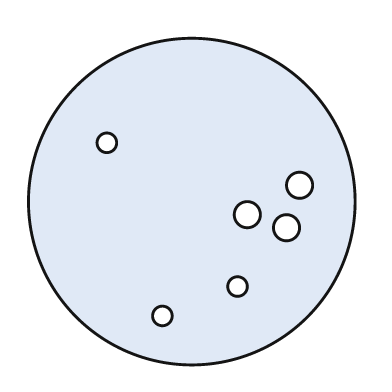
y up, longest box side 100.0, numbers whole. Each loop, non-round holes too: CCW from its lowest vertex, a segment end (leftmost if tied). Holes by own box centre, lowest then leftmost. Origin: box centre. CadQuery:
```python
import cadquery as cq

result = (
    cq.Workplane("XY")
    .moveTo(0.0, 0.0)
    .circle(50.0)
    .moveTo(-9.0, -35.0)
    .circle(3.0)
    .moveTo(14.0, -26.0)
    .circle(3.0)
    .moveTo(29.0, -8.0)
    .circle(4.0)
    .moveTo(17.0, -4.0)
    .circle(4.0)
    .moveTo(33.0, 5.0)
    .circle(4.0)
    .moveTo(-26.0, 18.0)
    .circle(3.0)
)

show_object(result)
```